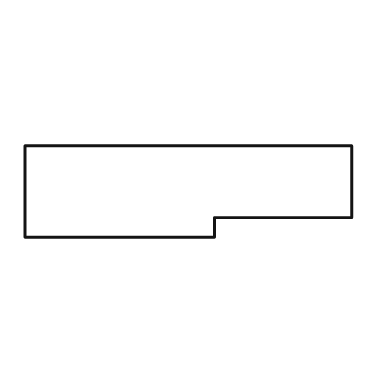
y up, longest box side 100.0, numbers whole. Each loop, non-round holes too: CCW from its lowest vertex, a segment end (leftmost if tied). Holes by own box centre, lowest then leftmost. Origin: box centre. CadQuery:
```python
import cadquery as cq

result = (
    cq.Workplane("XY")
    .moveTo(-50.0, -14.0)
    .lineTo(8.0, -14.0)
    .lineTo(8.0, -8.0)
    .lineTo(50.0, -8.0)
    .lineTo(50.0, 14.0)
    .lineTo(-50.0, 14.0)
    .close()
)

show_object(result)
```